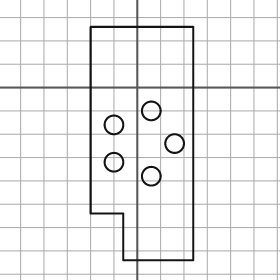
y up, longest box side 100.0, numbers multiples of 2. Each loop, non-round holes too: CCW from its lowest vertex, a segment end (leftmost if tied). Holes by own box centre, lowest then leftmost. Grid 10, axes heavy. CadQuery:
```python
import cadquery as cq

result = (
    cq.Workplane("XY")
    .moveTo(-6.0, -74.0)
    .lineTo(24.0, -74.0)
    .lineTo(24.0, 26.0)
    .lineTo(-20.0, 26.0)
    .lineTo(-20.0, -54.0)
    .lineTo(-6.0, -54.0)
    .close()
    .moveTo(6.0, -38.0)
    .circle(4.0)
    .moveTo(-10.0, -32.0)
    .circle(4.0)
    .moveTo(16.0, -24.0)
    .circle(4.0)
    .moveTo(-10.0, -16.0)
    .circle(4.0)
    .moveTo(6.0, -10.0)
    .circle(4.0)
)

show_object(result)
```